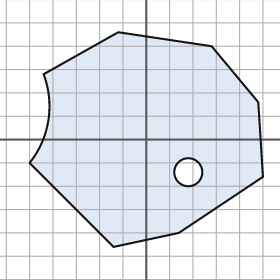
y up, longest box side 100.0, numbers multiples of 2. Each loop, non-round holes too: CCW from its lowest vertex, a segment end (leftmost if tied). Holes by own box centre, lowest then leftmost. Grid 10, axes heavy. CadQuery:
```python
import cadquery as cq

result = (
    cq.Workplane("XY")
    .moveTo(-14.0, -46.0)
    .lineTo(14.0, -40.0)
    .lineTo(50.0, -16.0)
    .lineTo(48.0, 16.0)
    .lineTo(28.0, 40.0)
    .lineTo(-12.0, 46.0)
    .lineTo(-44.0, 28.0)
    .threePointArc((-42.0, 8.0), (-50.0, -10.0))
    .close()
    .moveTo(18.0, -14.0)
    .circle(6.0)
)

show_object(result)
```